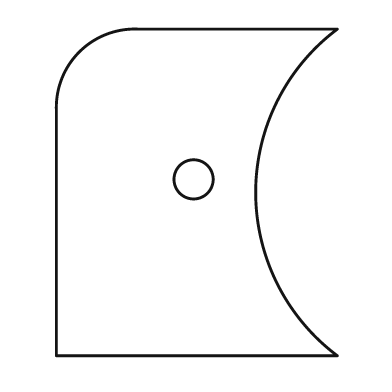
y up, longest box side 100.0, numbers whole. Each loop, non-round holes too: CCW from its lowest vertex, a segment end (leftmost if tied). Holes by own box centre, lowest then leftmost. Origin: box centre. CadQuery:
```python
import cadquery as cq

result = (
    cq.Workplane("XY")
    .moveTo(-43.0, -50.0)
    .lineTo(43.0, -50.0)
    .threePointArc((18.0, 0.0), (43.0, 50.0))
    .lineTo(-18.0, 50.0)
    .threePointArc((-36.0, 43.0), (-43.0, 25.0))
    .close()
    .moveTo(-1.0, 4.0)
    .circle(6.0)
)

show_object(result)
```